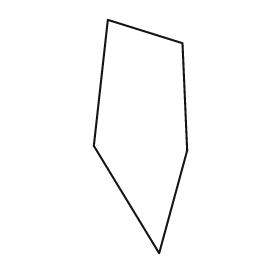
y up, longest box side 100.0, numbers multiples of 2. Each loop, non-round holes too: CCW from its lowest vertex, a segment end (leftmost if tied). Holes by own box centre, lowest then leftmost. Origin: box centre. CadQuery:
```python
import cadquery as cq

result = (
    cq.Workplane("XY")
    .moveTo(8.0, -50.0)
    .lineTo(20.0, -6.0)
    .lineTo(18.0, 40.0)
    .lineTo(-14.0, 50.0)
    .lineTo(-20.0, -4.0)
    .close()
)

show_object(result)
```